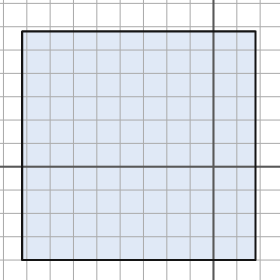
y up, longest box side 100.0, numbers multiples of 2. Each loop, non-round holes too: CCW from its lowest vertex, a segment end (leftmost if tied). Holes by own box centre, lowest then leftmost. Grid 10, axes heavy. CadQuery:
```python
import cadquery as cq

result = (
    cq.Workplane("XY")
    .moveTo(-82.0, -40.0)
    .lineTo(18.0, -40.0)
    .lineTo(18.0, 58.0)
    .lineTo(-82.0, 58.0)
    .close()
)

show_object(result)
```